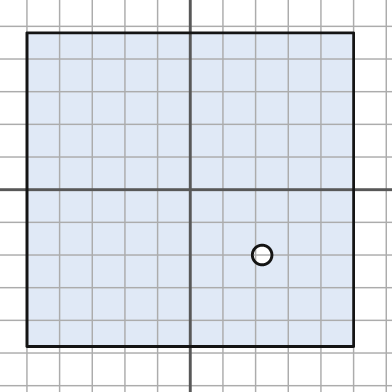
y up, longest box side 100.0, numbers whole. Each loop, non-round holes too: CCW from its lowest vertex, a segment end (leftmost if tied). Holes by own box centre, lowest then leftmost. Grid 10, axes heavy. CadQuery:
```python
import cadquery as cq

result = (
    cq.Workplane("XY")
    .moveTo(-50.0, -48.0)
    .lineTo(50.0, -48.0)
    .lineTo(50.0, 48.0)
    .lineTo(-50.0, 48.0)
    .close()
    .moveTo(22.0, -20.0)
    .circle(3.0)
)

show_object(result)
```